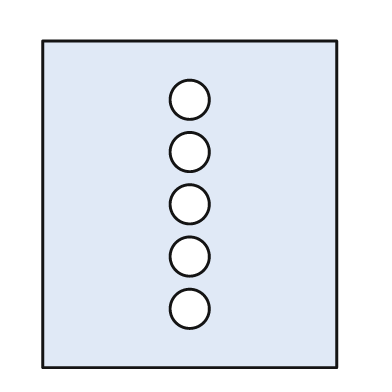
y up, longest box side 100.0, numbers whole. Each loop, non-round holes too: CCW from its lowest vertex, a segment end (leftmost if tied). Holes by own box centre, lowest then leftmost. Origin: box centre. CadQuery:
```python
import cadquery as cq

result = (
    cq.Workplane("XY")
    .moveTo(-45.0, -50.0)
    .lineTo(45.0, -50.0)
    .lineTo(45.0, 50.0)
    .lineTo(-45.0, 50.0)
    .close()
    .moveTo(0.0, -32.0)
    .circle(6.0)
    .moveTo(0.0, -16.0)
    .circle(6.0)
    .moveTo(0.0, 0.0)
    .circle(6.0)
    .moveTo(0.0, 16.0)
    .circle(6.0)
    .moveTo(0.0, 32.0)
    .circle(6.0)
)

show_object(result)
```